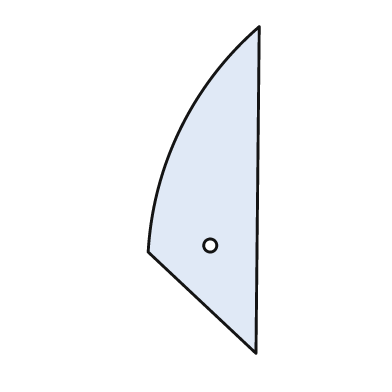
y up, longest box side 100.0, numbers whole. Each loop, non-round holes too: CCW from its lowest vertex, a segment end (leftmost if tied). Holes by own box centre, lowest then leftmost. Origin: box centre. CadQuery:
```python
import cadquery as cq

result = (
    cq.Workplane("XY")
    .moveTo(16.0, -50.0)
    .lineTo(17.0, 50.0)
    .threePointArc((-7.0, 19.0), (-17.0, -19.0))
    .close()
    .moveTo(2.0, -17.0)
    .circle(2.0)
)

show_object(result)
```